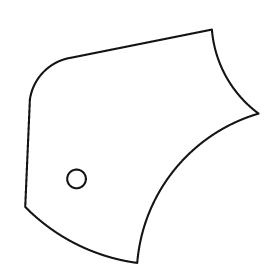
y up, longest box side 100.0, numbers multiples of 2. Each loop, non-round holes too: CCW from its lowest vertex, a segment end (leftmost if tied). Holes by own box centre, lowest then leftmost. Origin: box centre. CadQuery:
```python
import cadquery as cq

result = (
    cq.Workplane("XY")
    .moveTo(-2.0, -50.0)
    .threePointArc((14.0, -10.0), (50.0, 14.0))
    .threePointArc((36.0, 30.0), (30.0, 50.0))
    .lineTo(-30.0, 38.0)
    .threePointArc((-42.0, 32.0), (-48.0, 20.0))
    .lineTo(-50.0, -26.0)
    .threePointArc((-28.0, -42.0), (-2.0, -50.0))
    .close()
    .moveTo(-28.0, -14.0)
    .circle(4.0)
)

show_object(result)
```